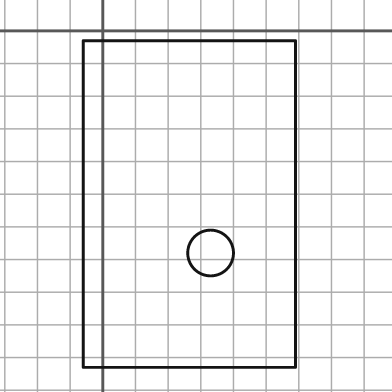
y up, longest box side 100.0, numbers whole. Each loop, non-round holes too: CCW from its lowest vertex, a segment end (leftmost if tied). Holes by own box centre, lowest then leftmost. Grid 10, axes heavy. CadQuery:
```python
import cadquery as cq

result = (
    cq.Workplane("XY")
    .moveTo(-6.0, -103.0)
    .lineTo(59.0, -103.0)
    .lineTo(59.0, -3.0)
    .lineTo(-6.0, -3.0)
    .close()
    .moveTo(33.0, -68.0)
    .circle(7.0)
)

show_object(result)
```